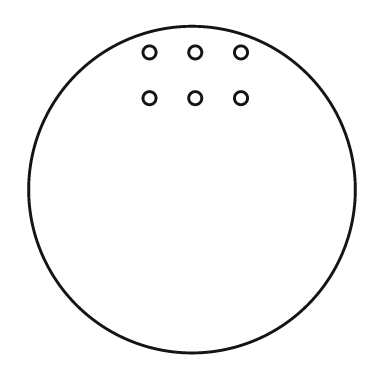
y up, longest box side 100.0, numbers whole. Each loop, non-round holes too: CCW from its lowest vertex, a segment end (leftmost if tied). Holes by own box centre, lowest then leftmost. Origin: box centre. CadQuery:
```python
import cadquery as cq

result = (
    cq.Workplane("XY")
    .moveTo(0.0, 0.0)
    .circle(50.0)
    .moveTo(-13.0, 28.0)
    .circle(2.0)
    .moveTo(1.0, 28.0)
    .circle(2.0)
    .moveTo(15.0, 28.0)
    .circle(2.0)
    .moveTo(-13.0, 42.0)
    .circle(2.0)
    .moveTo(1.0, 42.0)
    .circle(2.0)
    .moveTo(15.0, 42.0)
    .circle(2.0)
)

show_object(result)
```